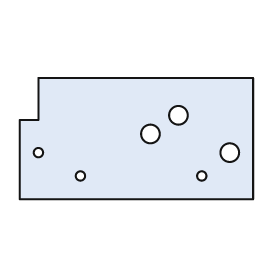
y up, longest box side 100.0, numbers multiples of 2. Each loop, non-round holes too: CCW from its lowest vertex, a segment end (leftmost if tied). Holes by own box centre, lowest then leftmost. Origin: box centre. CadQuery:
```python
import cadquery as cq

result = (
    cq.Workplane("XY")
    .moveTo(-50.0, -26.0)
    .lineTo(50.0, -26.0)
    .lineTo(50.0, 26.0)
    .lineTo(-42.0, 26.0)
    .lineTo(-42.0, 8.0)
    .lineTo(-50.0, 8.0)
    .close()
    .moveTo(-24.0, -16.0)
    .circle(2.0)
    .moveTo(28.0, -16.0)
    .circle(2.0)
    .moveTo(-42.0, -6.0)
    .circle(2.0)
    .moveTo(40.0, -6.0)
    .circle(4.0)
    .moveTo(6.0, 2.0)
    .circle(4.0)
    .moveTo(18.0, 10.0)
    .circle(4.0)
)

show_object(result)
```